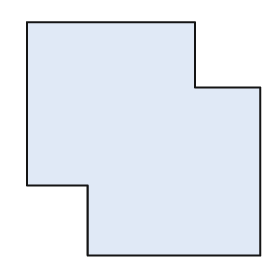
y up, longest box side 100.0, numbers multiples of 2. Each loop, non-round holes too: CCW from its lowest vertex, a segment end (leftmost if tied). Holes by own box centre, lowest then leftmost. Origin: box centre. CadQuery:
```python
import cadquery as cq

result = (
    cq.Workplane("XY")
    .moveTo(-24.0, -50.0)
    .lineTo(50.0, -50.0)
    .lineTo(50.0, 22.0)
    .lineTo(22.0, 22.0)
    .lineTo(22.0, 50.0)
    .lineTo(-50.0, 50.0)
    .lineTo(-50.0, -20.0)
    .lineTo(-24.0, -20.0)
    .close()
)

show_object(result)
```